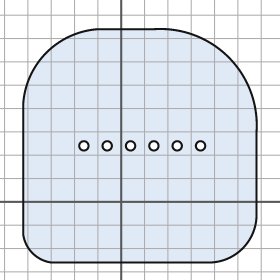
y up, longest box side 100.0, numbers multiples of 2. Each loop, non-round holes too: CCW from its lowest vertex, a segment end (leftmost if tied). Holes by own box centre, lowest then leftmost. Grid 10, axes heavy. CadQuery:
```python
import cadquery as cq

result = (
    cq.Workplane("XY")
    .moveTo(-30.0, -26.0)
    .lineTo(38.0, -26.0)
    .threePointArc((52.0, -20.0), (58.0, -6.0))
    .lineTo(58.0, 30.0)
    .threePointArc((46.0, 62.0), (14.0, 74.0))
    .lineTo(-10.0, 74.0)
    .threePointArc((-32.0, 64.0), (-42.0, 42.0))
    .lineTo(-42.0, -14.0)
    .threePointArc((-38.0, -22.0), (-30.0, -26.0))
    .close()
    .moveTo(-16.0, 24.0)
    .circle(2.0)
    .moveTo(-6.0, 24.0)
    .circle(2.0)
    .moveTo(4.0, 24.0)
    .circle(2.0)
    .moveTo(14.0, 24.0)
    .circle(2.0)
    .moveTo(24.0, 24.0)
    .circle(2.0)
    .moveTo(34.0, 24.0)
    .circle(2.0)
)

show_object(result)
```